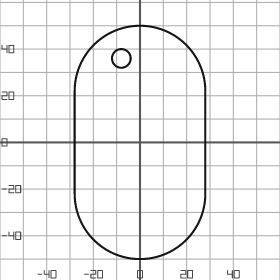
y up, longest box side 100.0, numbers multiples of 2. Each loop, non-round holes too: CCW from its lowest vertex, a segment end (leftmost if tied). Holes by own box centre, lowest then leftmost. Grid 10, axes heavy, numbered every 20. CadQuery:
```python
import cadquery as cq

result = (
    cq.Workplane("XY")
    .moveTo(-28.0, -22.0)
    .threePointArc((0.0, -50.0), (28.0, -22.0))
    .lineTo(28.0, 22.0)
    .threePointArc((0.0, 50.0), (-28.0, 22.0))
    .close()
    .moveTo(-8.0, 36.0)
    .circle(4.0)
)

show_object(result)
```